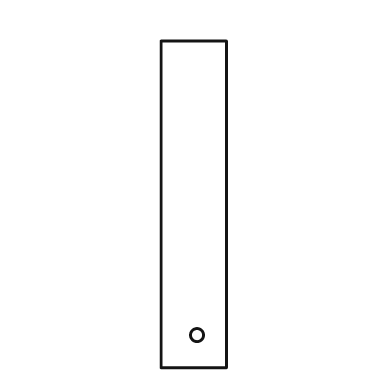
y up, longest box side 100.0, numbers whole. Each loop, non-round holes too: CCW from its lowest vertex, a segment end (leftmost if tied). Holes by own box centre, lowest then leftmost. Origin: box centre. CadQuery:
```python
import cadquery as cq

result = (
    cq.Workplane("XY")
    .moveTo(-10.0, -50.0)
    .lineTo(10.0, -50.0)
    .lineTo(10.0, 50.0)
    .lineTo(-10.0, 50.0)
    .close()
    .moveTo(1.0, -40.0)
    .circle(2.0)
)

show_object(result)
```